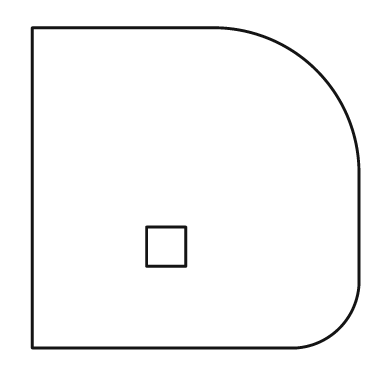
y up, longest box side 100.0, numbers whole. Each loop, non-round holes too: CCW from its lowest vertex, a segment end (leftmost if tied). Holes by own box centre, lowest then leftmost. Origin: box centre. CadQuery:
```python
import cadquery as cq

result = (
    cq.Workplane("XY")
    .moveTo(-50.0, -49.0)
    .lineTo(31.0, -49.0)
    .threePointArc((44.0, -43.0), (50.0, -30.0))
    .lineTo(50.0, 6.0)
    .threePointArc((37.0, 36.0), (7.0, 49.0))
    .lineTo(-50.0, 49.0)
    .close()
    .moveTo(-15.0, -24.0)
    .lineTo(-3.0, -24.0)
    .lineTo(-3.0, -12.0)
    .lineTo(-15.0, -12.0)
    .close()
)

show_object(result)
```